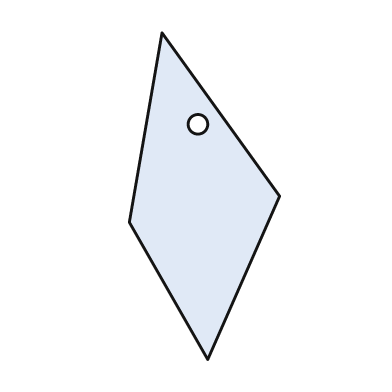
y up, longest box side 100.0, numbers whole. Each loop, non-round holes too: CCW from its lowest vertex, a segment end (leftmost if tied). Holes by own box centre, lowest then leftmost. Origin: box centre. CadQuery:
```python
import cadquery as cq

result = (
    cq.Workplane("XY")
    .moveTo(1.0, -50.0)
    .lineTo(23.0, 0.0)
    .lineTo(-13.0, 50.0)
    .lineTo(-23.0, -8.0)
    .close()
    .moveTo(-2.0, 22.0)
    .circle(3.0)
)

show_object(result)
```